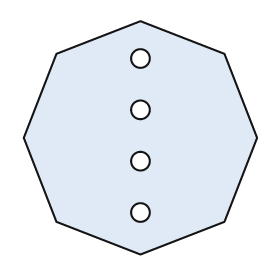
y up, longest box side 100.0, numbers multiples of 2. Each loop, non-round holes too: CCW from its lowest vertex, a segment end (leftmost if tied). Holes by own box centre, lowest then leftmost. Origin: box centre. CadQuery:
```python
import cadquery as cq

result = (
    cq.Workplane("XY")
    .moveTo(0.0, -50.0)
    .lineTo(36.0, -36.0)
    .lineTo(50.0, 0.0)
    .lineTo(36.0, 36.0)
    .lineTo(0.0, 50.0)
    .lineTo(-36.0, 36.0)
    .lineTo(-50.0, 0.0)
    .lineTo(-36.0, -36.0)
    .close()
    .moveTo(0.0, -32.0)
    .circle(4.0)
    .moveTo(0.0, -10.0)
    .circle(4.0)
    .moveTo(0.0, 12.0)
    .circle(4.0)
    .moveTo(0.0, 34.0)
    .circle(4.0)
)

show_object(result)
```